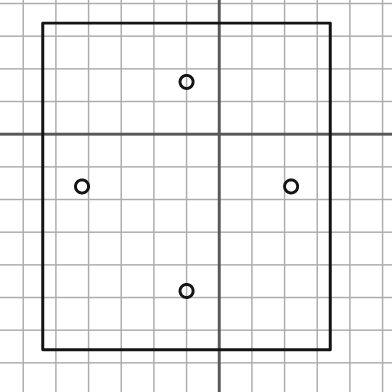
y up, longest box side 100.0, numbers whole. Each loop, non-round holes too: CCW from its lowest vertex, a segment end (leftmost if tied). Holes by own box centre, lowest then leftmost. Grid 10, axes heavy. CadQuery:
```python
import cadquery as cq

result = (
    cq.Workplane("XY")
    .moveTo(-54.0, -66.0)
    .lineTo(34.0, -66.0)
    .lineTo(34.0, 34.0)
    .lineTo(-54.0, 34.0)
    .close()
    .moveTo(-10.0, -48.0)
    .circle(2.0)
    .moveTo(-42.0, -16.0)
    .circle(2.0)
    .moveTo(22.0, -16.0)
    .circle(2.0)
    .moveTo(-10.0, 16.0)
    .circle(2.0)
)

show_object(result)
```